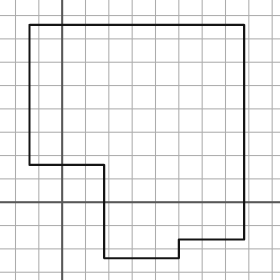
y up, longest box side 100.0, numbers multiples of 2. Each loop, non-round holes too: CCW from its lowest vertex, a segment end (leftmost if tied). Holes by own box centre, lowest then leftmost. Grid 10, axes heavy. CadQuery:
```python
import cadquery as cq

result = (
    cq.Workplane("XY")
    .moveTo(18.0, -24.0)
    .lineTo(50.0, -24.0)
    .lineTo(50.0, -16.0)
    .lineTo(78.0, -16.0)
    .lineTo(78.0, 76.0)
    .lineTo(-14.0, 76.0)
    .lineTo(-14.0, 16.0)
    .lineTo(18.0, 16.0)
    .close()
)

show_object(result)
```